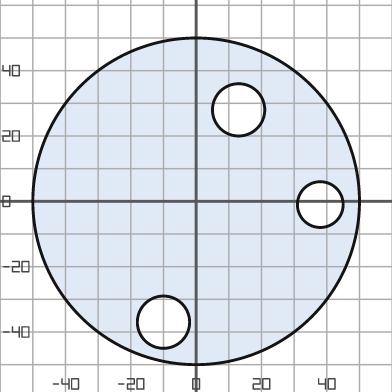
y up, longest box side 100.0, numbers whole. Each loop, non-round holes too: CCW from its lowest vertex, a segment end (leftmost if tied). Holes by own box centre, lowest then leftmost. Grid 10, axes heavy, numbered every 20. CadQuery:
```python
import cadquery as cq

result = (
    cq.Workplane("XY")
    .moveTo(0.0, 0.0)
    .circle(50.0)
    .moveTo(-10.0, -37.0)
    .circle(8.0)
    .moveTo(38.0, -1.0)
    .circle(7.0)
    .moveTo(13.0, 28.0)
    .circle(8.0)
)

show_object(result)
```